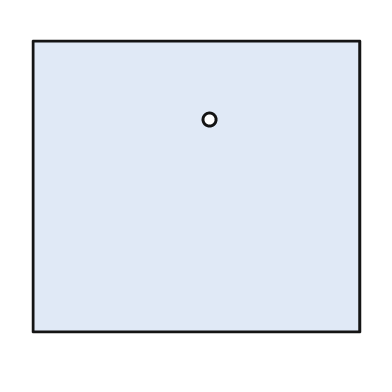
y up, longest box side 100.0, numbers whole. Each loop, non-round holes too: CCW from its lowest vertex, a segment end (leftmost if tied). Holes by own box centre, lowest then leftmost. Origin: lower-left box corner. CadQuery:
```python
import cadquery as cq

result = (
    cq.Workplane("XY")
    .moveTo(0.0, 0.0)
    .lineTo(100.0, 0.0)
    .lineTo(100.0, 89.0)
    .lineTo(0.0, 89.0)
    .close()
    .moveTo(54.0, 65.0)
    .circle(2.0)
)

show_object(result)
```